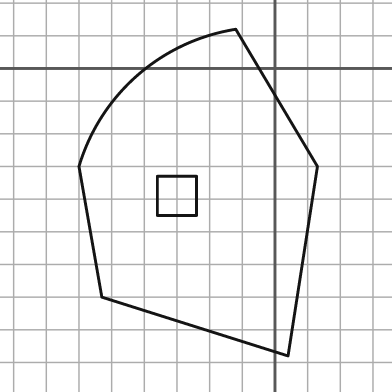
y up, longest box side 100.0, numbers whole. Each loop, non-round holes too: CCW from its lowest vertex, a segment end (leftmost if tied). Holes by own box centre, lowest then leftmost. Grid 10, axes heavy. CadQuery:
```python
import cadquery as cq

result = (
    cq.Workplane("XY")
    .moveTo(4.0, -88.0)
    .lineTo(13.0, -30.0)
    .lineTo(-12.0, 12.0)
    .threePointArc((-42.0, -2.0), (-60.0, -30.0))
    .lineTo(-53.0, -70.0)
    .close()
    .moveTo(-36.0, -45.0)
    .lineTo(-24.0, -45.0)
    .lineTo(-24.0, -33.0)
    .lineTo(-36.0, -33.0)
    .close()
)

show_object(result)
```